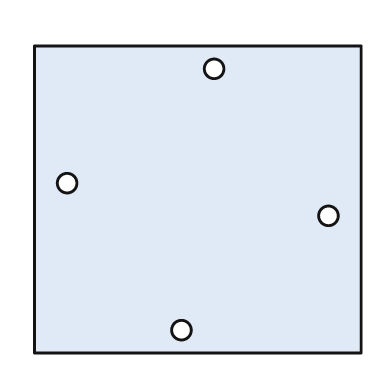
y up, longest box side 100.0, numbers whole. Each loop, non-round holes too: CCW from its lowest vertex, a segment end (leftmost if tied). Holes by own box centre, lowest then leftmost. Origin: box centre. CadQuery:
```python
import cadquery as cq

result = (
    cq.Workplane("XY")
    .moveTo(-50.0, -47.0)
    .lineTo(50.0, -47.0)
    .lineTo(50.0, 47.0)
    .lineTo(-50.0, 47.0)
    .close()
    .moveTo(-5.0, -40.0)
    .circle(3.0)
    .moveTo(40.0, -5.0)
    .circle(3.0)
    .moveTo(-40.0, 5.0)
    .circle(3.0)
    .moveTo(5.0, 40.0)
    .circle(3.0)
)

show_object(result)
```